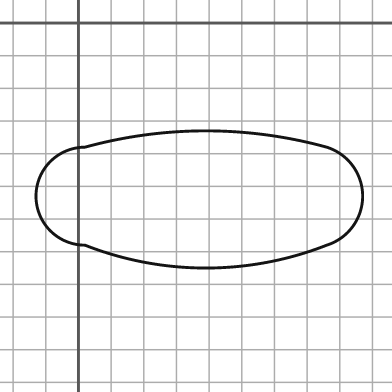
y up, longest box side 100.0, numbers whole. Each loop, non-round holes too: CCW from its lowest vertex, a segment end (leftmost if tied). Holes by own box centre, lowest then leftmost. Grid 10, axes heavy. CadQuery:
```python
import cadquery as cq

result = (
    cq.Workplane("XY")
    .moveTo(2.0, -68.0)
    .threePointArc((39.0, -75.0), (76.0, -68.0))
    .threePointArc((87.0, -53.0), (76.0, -38.0))
    .threePointArc((39.0, -33.0), (2.0, -38.0))
    .threePointArc((-13.0, -53.0), (2.0, -68.0))
    .close()
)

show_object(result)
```